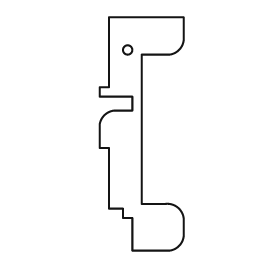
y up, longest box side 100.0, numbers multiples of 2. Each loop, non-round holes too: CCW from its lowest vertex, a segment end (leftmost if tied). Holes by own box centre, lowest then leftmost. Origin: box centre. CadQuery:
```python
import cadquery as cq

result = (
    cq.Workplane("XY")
    .moveTo(-4.0, -50.0)
    .lineTo(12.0, -50.0)
    .threePointArc((16.0, -48.0), (18.0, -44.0))
    .lineTo(18.0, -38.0)
    .threePointArc((16.0, -32.0), (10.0, -30.0))
    .lineTo(0.0, -30.0)
    .lineTo(0.0, 34.0)
    .lineTo(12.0, 34.0)
    .threePointArc((16.0, 36.0), (18.0, 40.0))
    .lineTo(18.0, 50.0)
    .lineTo(-14.0, 50.0)
    .lineTo(-14.0, 20.0)
    .lineTo(-18.0, 20.0)
    .lineTo(-18.0, 16.0)
    .lineTo(-4.0, 16.0)
    .lineTo(-4.0, 10.0)
    .lineTo(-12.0, 10.0)
    .threePointArc((-16.0, 8.0), (-18.0, 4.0))
    .lineTo(-18.0, -6.0)
    .lineTo(-14.0, -6.0)
    .lineTo(-14.0, -32.0)
    .lineTo(-8.0, -32.0)
    .lineTo(-8.0, -36.0)
    .lineTo(-4.0, -36.0)
    .close()
    .moveTo(-6.0, 36.0)
    .circle(2.0)
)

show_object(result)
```